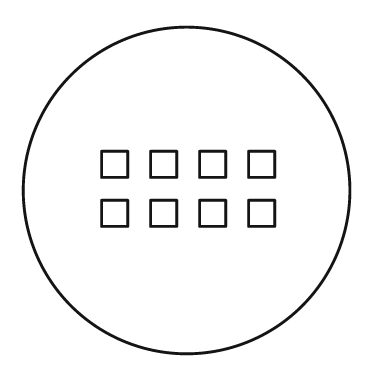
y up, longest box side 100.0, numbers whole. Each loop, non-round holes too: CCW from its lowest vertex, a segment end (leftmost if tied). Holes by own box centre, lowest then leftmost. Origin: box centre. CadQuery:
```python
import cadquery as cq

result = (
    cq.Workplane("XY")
    .moveTo(0.0, 0.0)
    .circle(50.0)
    .moveTo(-26.0, -11.0)
    .lineTo(-18.0, -11.0)
    .lineTo(-18.0, -3.0)
    .lineTo(-26.0, -3.0)
    .close()
    .moveTo(-11.0, -11.0)
    .lineTo(-3.0, -11.0)
    .lineTo(-3.0, -3.0)
    .lineTo(-11.0, -3.0)
    .close()
    .moveTo(4.0, -11.0)
    .lineTo(12.0, -11.0)
    .lineTo(12.0, -3.0)
    .lineTo(4.0, -3.0)
    .close()
    .moveTo(19.0, -11.0)
    .lineTo(27.0, -11.0)
    .lineTo(27.0, -3.0)
    .lineTo(19.0, -3.0)
    .close()
    .moveTo(-26.0, 4.0)
    .lineTo(-18.0, 4.0)
    .lineTo(-18.0, 12.0)
    .lineTo(-26.0, 12.0)
    .close()
    .moveTo(-11.0, 4.0)
    .lineTo(-3.0, 4.0)
    .lineTo(-3.0, 12.0)
    .lineTo(-11.0, 12.0)
    .close()
    .moveTo(4.0, 4.0)
    .lineTo(12.0, 4.0)
    .lineTo(12.0, 12.0)
    .lineTo(4.0, 12.0)
    .close()
    .moveTo(19.0, 4.0)
    .lineTo(27.0, 4.0)
    .lineTo(27.0, 12.0)
    .lineTo(19.0, 12.0)
    .close()
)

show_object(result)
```